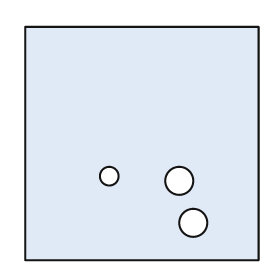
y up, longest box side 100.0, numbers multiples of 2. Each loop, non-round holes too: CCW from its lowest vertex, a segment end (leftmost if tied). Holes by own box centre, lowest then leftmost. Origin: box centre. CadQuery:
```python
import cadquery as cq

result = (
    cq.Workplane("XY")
    .moveTo(-50.0, -50.0)
    .lineTo(50.0, -50.0)
    .lineTo(50.0, 50.0)
    .lineTo(-50.0, 50.0)
    .close()
    .moveTo(22.0, -34.0)
    .circle(6.0)
    .moveTo(16.0, -16.0)
    .circle(6.0)
    .moveTo(-14.0, -14.0)
    .circle(4.0)
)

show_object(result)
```